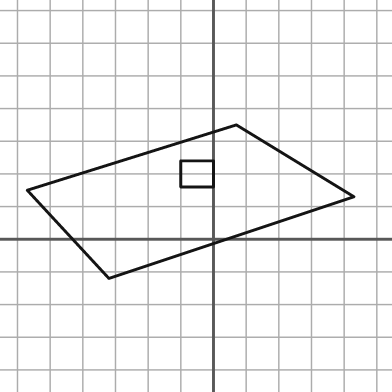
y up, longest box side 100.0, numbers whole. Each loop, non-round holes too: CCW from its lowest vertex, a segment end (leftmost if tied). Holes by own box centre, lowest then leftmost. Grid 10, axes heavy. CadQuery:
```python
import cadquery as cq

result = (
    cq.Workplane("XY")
    .moveTo(-32.0, -12.0)
    .lineTo(43.0, 13.0)
    .lineTo(7.0, 35.0)
    .lineTo(-57.0, 15.0)
    .close()
    .moveTo(-10.0, 16.0)
    .lineTo(0.0, 16.0)
    .lineTo(0.0, 24.0)
    .lineTo(-10.0, 24.0)
    .close()
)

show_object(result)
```